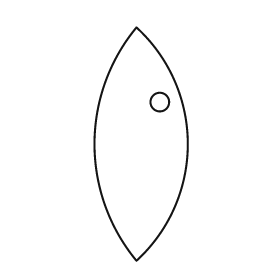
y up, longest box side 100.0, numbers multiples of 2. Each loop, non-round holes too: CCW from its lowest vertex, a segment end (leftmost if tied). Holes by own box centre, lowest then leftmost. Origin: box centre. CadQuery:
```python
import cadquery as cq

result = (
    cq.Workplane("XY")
    .moveTo(-2.0, -50.0)
    .threePointArc((20.0, 0.0), (-2.0, 50.0))
    .threePointArc((-20.0, 0.0), (-2.0, -50.0))
    .close()
    .moveTo(8.0, 18.0)
    .circle(4.0)
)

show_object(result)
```